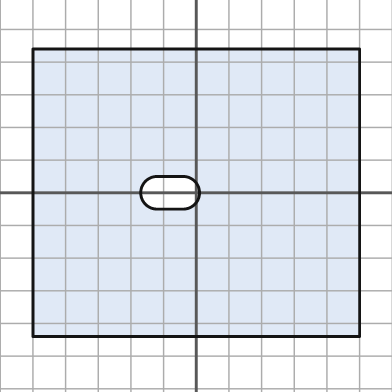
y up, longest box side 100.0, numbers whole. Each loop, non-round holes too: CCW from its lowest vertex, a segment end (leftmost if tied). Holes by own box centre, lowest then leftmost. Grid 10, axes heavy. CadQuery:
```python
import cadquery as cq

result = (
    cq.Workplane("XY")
    .moveTo(-50.0, -44.0)
    .lineTo(50.0, -44.0)
    .lineTo(50.0, 44.0)
    .lineTo(-50.0, 44.0)
    .close()
    .moveTo(-12.0, -5.0)
    .lineTo(-4.0, -5.0)
    .threePointArc((1.0, 0.0), (-4.0, 5.0))
    .lineTo(-12.0, 5.0)
    .threePointArc((-17.0, 0.0), (-12.0, -5.0))
    .close()
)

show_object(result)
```